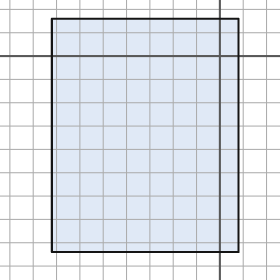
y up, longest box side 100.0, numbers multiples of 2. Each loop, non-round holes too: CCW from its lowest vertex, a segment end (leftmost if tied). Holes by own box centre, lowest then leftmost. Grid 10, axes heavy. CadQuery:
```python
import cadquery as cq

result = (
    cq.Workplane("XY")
    .moveTo(-72.0, -84.0)
    .lineTo(8.0, -84.0)
    .lineTo(8.0, 16.0)
    .lineTo(-72.0, 16.0)
    .close()
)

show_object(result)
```